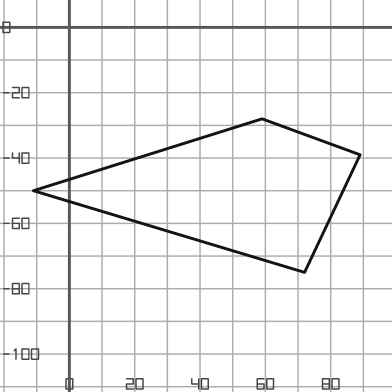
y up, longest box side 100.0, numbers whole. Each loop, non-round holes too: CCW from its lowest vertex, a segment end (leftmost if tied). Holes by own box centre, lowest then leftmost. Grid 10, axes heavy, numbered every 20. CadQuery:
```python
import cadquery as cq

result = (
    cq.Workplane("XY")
    .moveTo(72.0, -75.0)
    .lineTo(89.0, -39.0)
    .lineTo(59.0, -28.0)
    .lineTo(-11.0, -50.0)
    .close()
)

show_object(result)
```